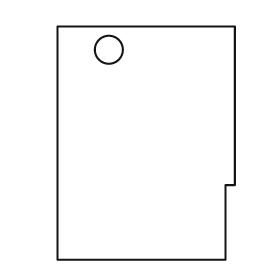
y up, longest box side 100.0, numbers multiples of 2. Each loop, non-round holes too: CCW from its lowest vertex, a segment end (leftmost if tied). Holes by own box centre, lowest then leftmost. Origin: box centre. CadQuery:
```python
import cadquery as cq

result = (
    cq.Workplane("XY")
    .moveTo(-38.0, -50.0)
    .lineTo(34.0, -50.0)
    .lineTo(34.0, -18.0)
    .lineTo(38.0, -18.0)
    .lineTo(38.0, 50.0)
    .lineTo(-38.0, 50.0)
    .close()
    .moveTo(-16.0, 40.0)
    .circle(6.0)
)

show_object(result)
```